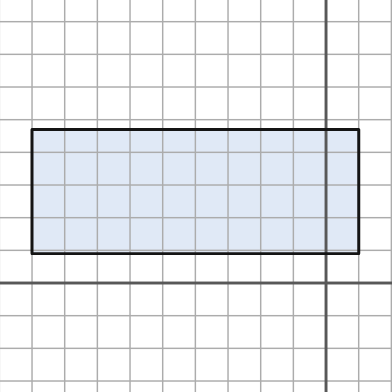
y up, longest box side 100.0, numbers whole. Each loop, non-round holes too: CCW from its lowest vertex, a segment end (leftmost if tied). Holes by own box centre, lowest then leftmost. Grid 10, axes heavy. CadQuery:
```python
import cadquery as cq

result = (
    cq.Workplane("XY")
    .moveTo(-90.0, 9.0)
    .lineTo(10.0, 9.0)
    .lineTo(10.0, 47.0)
    .lineTo(-90.0, 47.0)
    .close()
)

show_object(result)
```